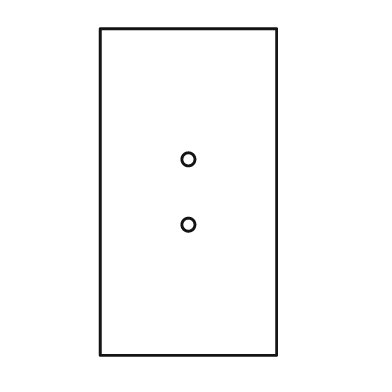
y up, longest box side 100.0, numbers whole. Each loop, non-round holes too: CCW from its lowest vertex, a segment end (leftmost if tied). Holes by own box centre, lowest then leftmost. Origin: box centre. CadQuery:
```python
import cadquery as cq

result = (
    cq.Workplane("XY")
    .moveTo(-27.0, -50.0)
    .lineTo(27.0, -50.0)
    .lineTo(27.0, 50.0)
    .lineTo(-27.0, 50.0)
    .close()
    .moveTo(0.0, -10.0)
    .circle(2.0)
    .moveTo(0.0, 10.0)
    .circle(2.0)
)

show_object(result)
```